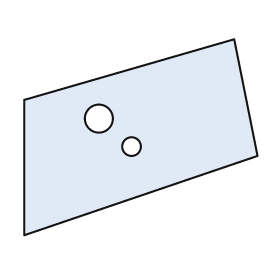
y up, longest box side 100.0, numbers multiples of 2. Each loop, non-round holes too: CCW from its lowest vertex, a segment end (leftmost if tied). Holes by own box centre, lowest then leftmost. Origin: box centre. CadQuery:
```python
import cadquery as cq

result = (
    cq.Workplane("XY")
    .moveTo(-50.0, -42.0)
    .lineTo(50.0, -8.0)
    .lineTo(40.0, 42.0)
    .lineTo(-50.0, 16.0)
    .close()
    .moveTo(-4.0, -4.0)
    .circle(4.0)
    .moveTo(-18.0, 8.0)
    .circle(6.0)
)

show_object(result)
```